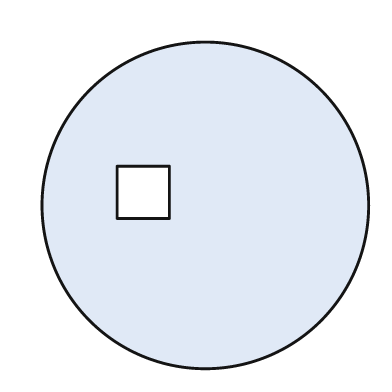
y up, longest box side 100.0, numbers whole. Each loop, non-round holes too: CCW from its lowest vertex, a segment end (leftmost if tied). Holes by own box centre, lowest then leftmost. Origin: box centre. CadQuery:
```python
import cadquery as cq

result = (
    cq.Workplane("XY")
    .moveTo(0.0, 0.0)
    .circle(50.0)
    .moveTo(-27.0, -4.0)
    .lineTo(-11.0, -4.0)
    .lineTo(-11.0, 12.0)
    .lineTo(-27.0, 12.0)
    .close()
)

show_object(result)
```